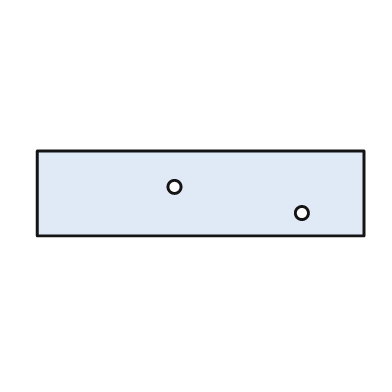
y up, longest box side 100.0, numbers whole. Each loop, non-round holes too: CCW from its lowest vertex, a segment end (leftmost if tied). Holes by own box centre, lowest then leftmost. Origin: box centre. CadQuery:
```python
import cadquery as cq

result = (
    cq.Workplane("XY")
    .moveTo(-50.0, -13.0)
    .lineTo(50.0, -13.0)
    .lineTo(50.0, 13.0)
    .lineTo(-50.0, 13.0)
    .close()
    .moveTo(31.0, -6.0)
    .circle(2.0)
    .moveTo(-8.0, 2.0)
    .circle(2.0)
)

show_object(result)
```